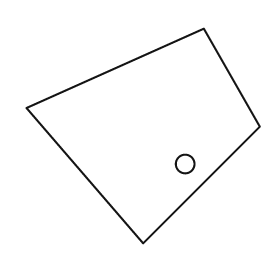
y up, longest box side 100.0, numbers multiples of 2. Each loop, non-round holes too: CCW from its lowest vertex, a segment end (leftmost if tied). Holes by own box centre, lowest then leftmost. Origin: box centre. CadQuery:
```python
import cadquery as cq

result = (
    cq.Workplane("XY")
    .moveTo(0.0, -46.0)
    .lineTo(50.0, 4.0)
    .lineTo(26.0, 46.0)
    .lineTo(-50.0, 12.0)
    .close()
    .moveTo(18.0, -12.0)
    .circle(4.0)
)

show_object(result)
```